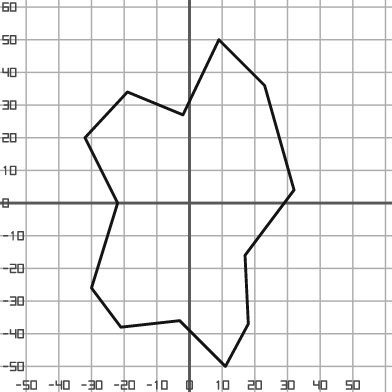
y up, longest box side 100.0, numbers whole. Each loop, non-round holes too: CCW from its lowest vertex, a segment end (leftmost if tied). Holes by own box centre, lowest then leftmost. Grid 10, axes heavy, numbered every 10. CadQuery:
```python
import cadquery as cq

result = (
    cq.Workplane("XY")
    .moveTo(11.0, -50.0)
    .lineTo(18.0, -37.0)
    .lineTo(17.0, -16.0)
    .lineTo(32.0, 4.0)
    .lineTo(23.0, 36.0)
    .lineTo(9.0, 50.0)
    .lineTo(-2.0, 27.0)
    .lineTo(-19.0, 34.0)
    .lineTo(-32.0, 20.0)
    .lineTo(-22.0, 0.0)
    .lineTo(-30.0, -26.0)
    .lineTo(-21.0, -38.0)
    .lineTo(-3.0, -36.0)
    .close()
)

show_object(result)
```